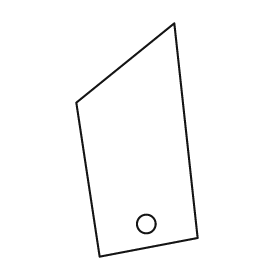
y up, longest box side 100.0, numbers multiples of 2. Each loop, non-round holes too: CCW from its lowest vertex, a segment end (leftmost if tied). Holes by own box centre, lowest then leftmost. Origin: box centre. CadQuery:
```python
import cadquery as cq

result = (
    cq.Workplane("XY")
    .moveTo(-16.0, -50.0)
    .lineTo(26.0, -42.0)
    .lineTo(16.0, 50.0)
    .lineTo(-26.0, 16.0)
    .close()
    .moveTo(4.0, -36.0)
    .circle(4.0)
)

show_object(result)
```